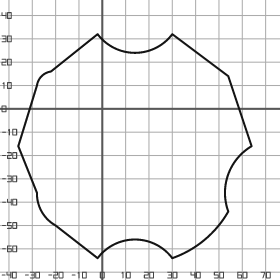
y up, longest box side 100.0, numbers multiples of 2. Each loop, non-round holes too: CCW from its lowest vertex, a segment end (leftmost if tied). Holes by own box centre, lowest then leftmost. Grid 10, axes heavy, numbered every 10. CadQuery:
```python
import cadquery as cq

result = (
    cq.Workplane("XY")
    .moveTo(-2.0, -64.0)
    .threePointArc((14.0, -56.0), (30.0, -64.0))
    .threePointArc((44.0, -56.0), (54.0, -44.0))
    .threePointArc((54.0, -28.0), (64.0, -16.0))
    .lineTo(54.0, 14.0)
    .lineTo(30.0, 32.0)
    .threePointArc((14.0, 24.0), (-2.0, 32.0))
    .lineTo(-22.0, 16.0)
    .threePointArc((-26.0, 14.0), (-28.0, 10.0))
    .lineTo(-36.0, -16.0)
    .lineTo(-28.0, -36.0)
    .threePointArc((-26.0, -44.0), (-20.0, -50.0))
    .close()
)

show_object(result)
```